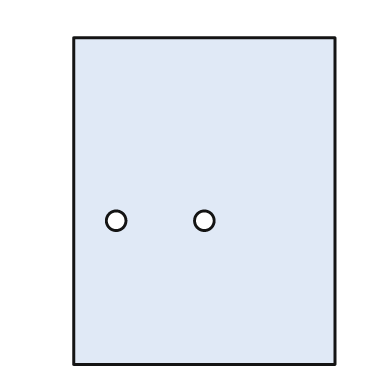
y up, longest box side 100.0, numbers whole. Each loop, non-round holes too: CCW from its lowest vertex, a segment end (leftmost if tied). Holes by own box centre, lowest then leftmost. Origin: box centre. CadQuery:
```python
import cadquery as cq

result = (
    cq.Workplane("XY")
    .moveTo(-40.0, -50.0)
    .lineTo(40.0, -50.0)
    .lineTo(40.0, 50.0)
    .lineTo(-40.0, 50.0)
    .close()
    .moveTo(-27.0, -6.0)
    .circle(3.0)
    .moveTo(0.0, -6.0)
    .circle(3.0)
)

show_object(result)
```